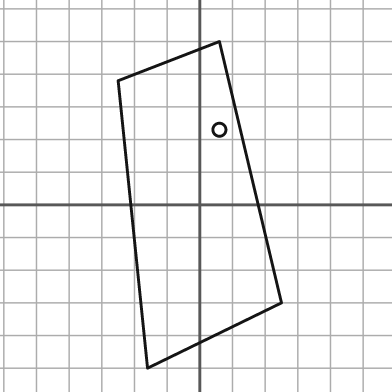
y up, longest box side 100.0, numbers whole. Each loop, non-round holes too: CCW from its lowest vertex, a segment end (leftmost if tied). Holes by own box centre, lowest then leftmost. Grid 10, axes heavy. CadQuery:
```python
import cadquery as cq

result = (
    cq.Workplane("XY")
    .moveTo(-16.0, -50.0)
    .lineTo(25.0, -30.0)
    .lineTo(6.0, 50.0)
    .lineTo(-25.0, 38.0)
    .close()
    .moveTo(6.0, 23.0)
    .circle(2.0)
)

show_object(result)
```